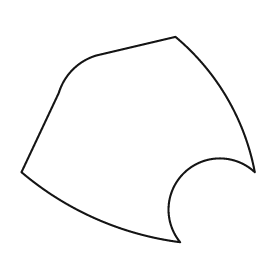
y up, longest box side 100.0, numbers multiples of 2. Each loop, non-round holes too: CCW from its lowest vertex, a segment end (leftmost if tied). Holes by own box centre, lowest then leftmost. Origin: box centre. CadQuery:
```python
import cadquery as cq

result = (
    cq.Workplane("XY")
    .moveTo(18.0, -44.0)
    .threePointArc((20.0, -14.0), (50.0, -14.0))
    .threePointArc((38.0, 18.0), (16.0, 44.0))
    .lineTo(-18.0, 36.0)
    .threePointArc((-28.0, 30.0), (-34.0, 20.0))
    .lineTo(-50.0, -14.0)
    .threePointArc((-18.0, -34.0), (18.0, -44.0))
    .close()
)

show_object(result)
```